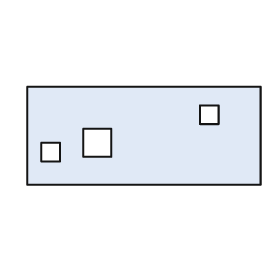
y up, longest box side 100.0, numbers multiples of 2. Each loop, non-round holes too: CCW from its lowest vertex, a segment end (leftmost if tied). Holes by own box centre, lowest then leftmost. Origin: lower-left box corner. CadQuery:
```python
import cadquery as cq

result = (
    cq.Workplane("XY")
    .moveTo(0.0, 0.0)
    .lineTo(100.0, 0.0)
    .lineTo(100.0, 42.0)
    .lineTo(0.0, 42.0)
    .close()
    .moveTo(6.0, 10.0)
    .lineTo(14.0, 10.0)
    .lineTo(14.0, 18.0)
    .lineTo(6.0, 18.0)
    .close()
    .moveTo(24.0, 12.0)
    .lineTo(36.0, 12.0)
    .lineTo(36.0, 24.0)
    .lineTo(24.0, 24.0)
    .close()
    .moveTo(74.0, 26.0)
    .lineTo(82.0, 26.0)
    .lineTo(82.0, 34.0)
    .lineTo(74.0, 34.0)
    .close()
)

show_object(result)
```